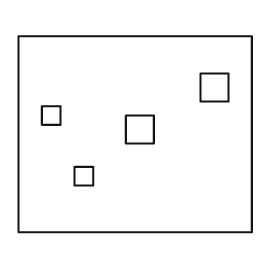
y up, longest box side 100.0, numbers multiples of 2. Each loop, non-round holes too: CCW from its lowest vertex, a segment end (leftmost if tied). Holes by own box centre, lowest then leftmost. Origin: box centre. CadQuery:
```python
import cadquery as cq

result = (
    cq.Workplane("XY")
    .moveTo(-50.0, -42.0)
    .lineTo(50.0, -42.0)
    .lineTo(50.0, 42.0)
    .lineTo(-50.0, 42.0)
    .close()
    .moveTo(-26.0, -22.0)
    .lineTo(-18.0, -22.0)
    .lineTo(-18.0, -14.0)
    .lineTo(-26.0, -14.0)
    .close()
    .moveTo(-4.0, -4.0)
    .lineTo(8.0, -4.0)
    .lineTo(8.0, 8.0)
    .lineTo(-4.0, 8.0)
    .close()
    .moveTo(-40.0, 4.0)
    .lineTo(-32.0, 4.0)
    .lineTo(-32.0, 12.0)
    .lineTo(-40.0, 12.0)
    .close()
    .moveTo(28.0, 14.0)
    .lineTo(40.0, 14.0)
    .lineTo(40.0, 26.0)
    .lineTo(28.0, 26.0)
    .close()
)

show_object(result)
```